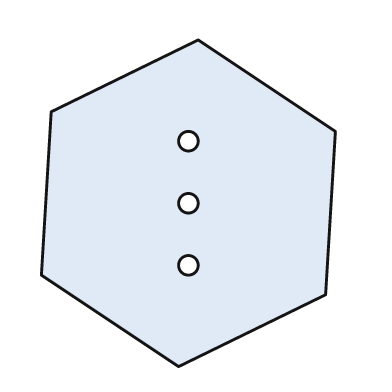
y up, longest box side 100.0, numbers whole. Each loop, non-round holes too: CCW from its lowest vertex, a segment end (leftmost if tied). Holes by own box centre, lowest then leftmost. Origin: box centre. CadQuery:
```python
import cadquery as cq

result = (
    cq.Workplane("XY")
    .moveTo(-3.0, -50.0)
    .lineTo(42.0, -28.0)
    .lineTo(45.0, 22.0)
    .lineTo(3.0, 50.0)
    .lineTo(-42.0, 28.0)
    .lineTo(-45.0, -22.0)
    .close()
    .moveTo(0.0, -19.0)
    .circle(3.0)
    .moveTo(0.0, 0.0)
    .circle(3.0)
    .moveTo(0.0, 19.0)
    .circle(3.0)
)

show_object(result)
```